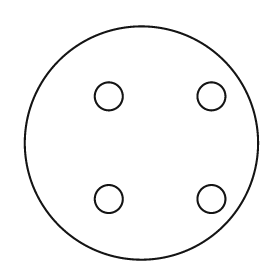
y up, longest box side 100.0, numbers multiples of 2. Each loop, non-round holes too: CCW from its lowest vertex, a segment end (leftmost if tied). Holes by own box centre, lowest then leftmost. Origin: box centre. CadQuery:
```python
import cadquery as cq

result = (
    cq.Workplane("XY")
    .moveTo(0.0, 0.0)
    .circle(50.0)
    .moveTo(-14.0, -24.0)
    .circle(6.0)
    .moveTo(30.0, -24.0)
    .circle(6.0)
    .moveTo(-14.0, 20.0)
    .circle(6.0)
    .moveTo(30.0, 20.0)
    .circle(6.0)
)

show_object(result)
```